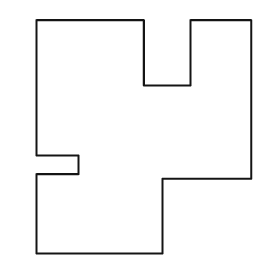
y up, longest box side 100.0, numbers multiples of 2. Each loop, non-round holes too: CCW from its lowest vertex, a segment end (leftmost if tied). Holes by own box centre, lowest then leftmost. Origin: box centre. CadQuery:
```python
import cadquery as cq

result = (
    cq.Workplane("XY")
    .moveTo(-46.0, -50.0)
    .lineTo(8.0, -50.0)
    .lineTo(8.0, -18.0)
    .lineTo(46.0, -18.0)
    .lineTo(46.0, 50.0)
    .lineTo(20.0, 50.0)
    .lineTo(20.0, 22.0)
    .lineTo(0.0, 22.0)
    .lineTo(0.0, 50.0)
    .lineTo(-46.0, 50.0)
    .lineTo(-46.0, -8.0)
    .lineTo(-28.0, -8.0)
    .lineTo(-28.0, -16.0)
    .lineTo(-46.0, -16.0)
    .close()
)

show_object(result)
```